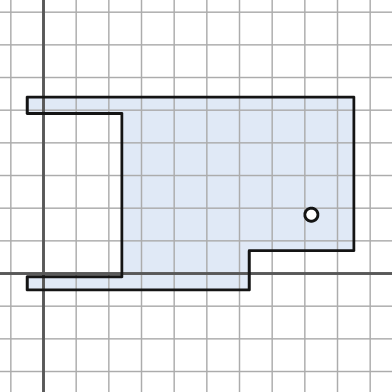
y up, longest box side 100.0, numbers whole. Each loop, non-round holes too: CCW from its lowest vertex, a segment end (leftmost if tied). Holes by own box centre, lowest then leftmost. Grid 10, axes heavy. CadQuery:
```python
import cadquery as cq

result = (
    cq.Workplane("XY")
    .moveTo(-5.0, -5.0)
    .lineTo(63.0, -5.0)
    .lineTo(63.0, 7.0)
    .lineTo(95.0, 7.0)
    .lineTo(95.0, 54.0)
    .lineTo(-5.0, 54.0)
    .lineTo(-5.0, 49.0)
    .lineTo(24.0, 49.0)
    .lineTo(24.0, -1.0)
    .lineTo(-5.0, -1.0)
    .close()
    .moveTo(82.0, 18.0)
    .circle(2.0)
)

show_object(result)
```